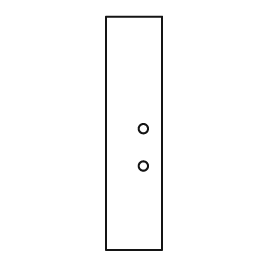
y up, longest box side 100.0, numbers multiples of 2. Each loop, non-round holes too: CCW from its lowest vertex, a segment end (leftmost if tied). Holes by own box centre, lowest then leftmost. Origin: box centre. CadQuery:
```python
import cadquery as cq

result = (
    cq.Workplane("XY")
    .moveTo(-12.0, -50.0)
    .lineTo(12.0, -50.0)
    .lineTo(12.0, 50.0)
    .lineTo(-12.0, 50.0)
    .close()
    .moveTo(4.0, -14.0)
    .circle(2.0)
    .moveTo(4.0, 2.0)
    .circle(2.0)
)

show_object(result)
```